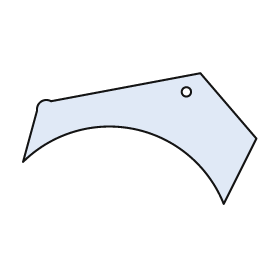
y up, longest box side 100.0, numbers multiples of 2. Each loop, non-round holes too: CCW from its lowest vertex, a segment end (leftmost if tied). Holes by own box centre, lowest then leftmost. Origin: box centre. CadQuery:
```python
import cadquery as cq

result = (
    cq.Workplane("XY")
    .moveTo(36.0, -28.0)
    .lineTo(50.0, 0.0)
    .lineTo(26.0, 28.0)
    .lineTo(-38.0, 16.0)
    .threePointArc((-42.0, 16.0), (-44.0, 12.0))
    .lineTo(-50.0, -10.0)
    .threePointArc((-2.0, 4.0), (36.0, -28.0))
    .close()
    .moveTo(20.0, 20.0)
    .circle(2.0)
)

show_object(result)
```